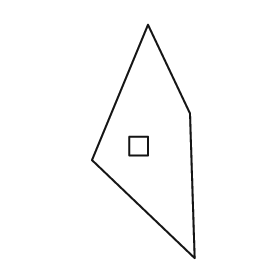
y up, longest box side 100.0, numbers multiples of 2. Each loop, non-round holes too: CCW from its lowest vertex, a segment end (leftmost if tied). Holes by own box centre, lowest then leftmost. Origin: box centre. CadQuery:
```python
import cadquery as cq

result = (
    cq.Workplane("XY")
    .moveTo(22.0, -50.0)
    .lineTo(20.0, 12.0)
    .lineTo(2.0, 50.0)
    .lineTo(-22.0, -8.0)
    .close()
    .moveTo(-6.0, -6.0)
    .lineTo(2.0, -6.0)
    .lineTo(2.0, 2.0)
    .lineTo(-6.0, 2.0)
    .close()
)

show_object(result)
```